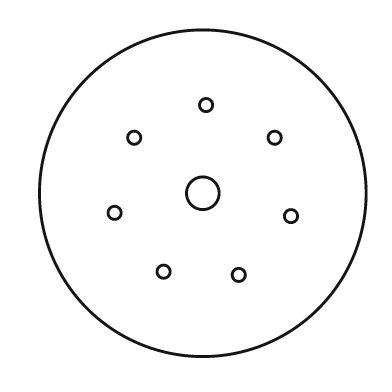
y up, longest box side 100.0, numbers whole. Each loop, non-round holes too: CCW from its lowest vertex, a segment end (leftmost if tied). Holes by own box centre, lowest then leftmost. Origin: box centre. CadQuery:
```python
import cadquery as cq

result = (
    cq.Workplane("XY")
    .moveTo(0.0, 0.0)
    .circle(50.0)
    .moveTo(11.0, -25.0)
    .circle(2.0)
    .moveTo(-12.0, -24.0)
    .circle(2.0)
    .moveTo(27.0, -7.0)
    .circle(2.0)
    .moveTo(-27.0, -6.0)
    .circle(2.0)
    .moveTo(0.0, 0.0)
    .circle(5.0)
    .moveTo(-21.0, 17.0)
    .circle(2.0)
    .moveTo(22.0, 17.0)
    .circle(2.0)
    .moveTo(1.0, 27.0)
    .circle(2.0)
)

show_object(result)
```